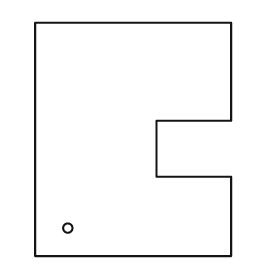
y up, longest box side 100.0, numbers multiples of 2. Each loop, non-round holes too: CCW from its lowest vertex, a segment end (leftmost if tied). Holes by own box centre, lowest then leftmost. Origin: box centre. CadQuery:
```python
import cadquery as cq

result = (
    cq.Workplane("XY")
    .moveTo(-42.0, -50.0)
    .lineTo(42.0, -50.0)
    .lineTo(42.0, -16.0)
    .lineTo(10.0, -16.0)
    .lineTo(10.0, 8.0)
    .lineTo(42.0, 8.0)
    .lineTo(42.0, 50.0)
    .lineTo(-42.0, 50.0)
    .close()
    .moveTo(-28.0, -38.0)
    .circle(2.0)
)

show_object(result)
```